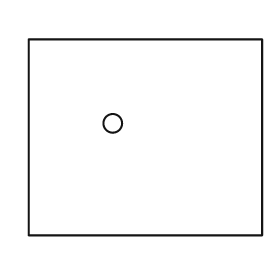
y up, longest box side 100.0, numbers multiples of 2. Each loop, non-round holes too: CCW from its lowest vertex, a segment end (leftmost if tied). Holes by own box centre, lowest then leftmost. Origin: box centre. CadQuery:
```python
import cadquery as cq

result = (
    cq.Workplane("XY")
    .moveTo(-50.0, -42.0)
    .lineTo(50.0, -42.0)
    .lineTo(50.0, 42.0)
    .lineTo(-50.0, 42.0)
    .close()
    .moveTo(-14.0, 6.0)
    .circle(4.0)
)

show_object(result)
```